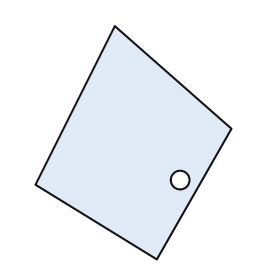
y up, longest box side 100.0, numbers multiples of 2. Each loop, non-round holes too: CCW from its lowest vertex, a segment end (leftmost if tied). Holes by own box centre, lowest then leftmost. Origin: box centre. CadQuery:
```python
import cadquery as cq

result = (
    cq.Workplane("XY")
    .moveTo(10.0, -50.0)
    .lineTo(42.0, 6.0)
    .lineTo(-8.0, 50.0)
    .lineTo(-42.0, -18.0)
    .close()
    .moveTo(20.0, -16.0)
    .circle(4.0)
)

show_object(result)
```